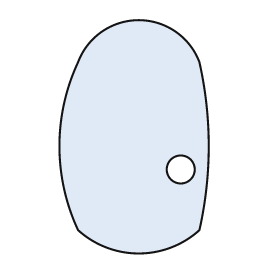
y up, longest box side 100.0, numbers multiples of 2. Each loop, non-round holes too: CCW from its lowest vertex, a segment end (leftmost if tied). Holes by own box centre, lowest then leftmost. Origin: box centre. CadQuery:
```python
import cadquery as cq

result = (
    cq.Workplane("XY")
    .moveTo(-24.0, -40.0)
    .threePointArc((2.0, -50.0), (28.0, -40.0))
    .threePointArc((32.0, -4.0), (28.0, 32.0))
    .threePointArc((2.0, 50.0), (-24.0, 32.0))
    .threePointArc((-32.0, -4.0), (-24.0, -40.0))
    .close()
    .moveTo(20.0, -14.0)
    .circle(6.0)
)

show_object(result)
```